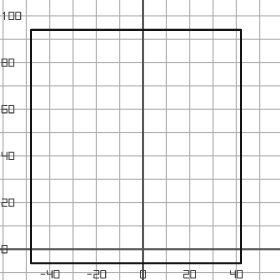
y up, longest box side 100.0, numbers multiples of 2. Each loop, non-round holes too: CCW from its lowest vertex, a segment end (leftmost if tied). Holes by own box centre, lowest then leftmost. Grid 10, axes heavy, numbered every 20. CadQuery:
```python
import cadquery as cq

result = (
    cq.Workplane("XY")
    .moveTo(-48.0, -6.0)
    .lineTo(42.0, -6.0)
    .lineTo(42.0, 94.0)
    .lineTo(-48.0, 94.0)
    .close()
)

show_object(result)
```